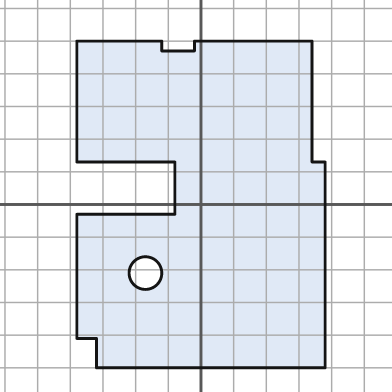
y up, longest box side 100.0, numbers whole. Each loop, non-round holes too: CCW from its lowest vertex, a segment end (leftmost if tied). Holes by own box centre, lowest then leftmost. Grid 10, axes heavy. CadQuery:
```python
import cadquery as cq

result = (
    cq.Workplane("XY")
    .moveTo(-32.0, -50.0)
    .lineTo(38.0, -50.0)
    .lineTo(38.0, 13.0)
    .lineTo(34.0, 13.0)
    .lineTo(34.0, 50.0)
    .lineTo(-2.0, 50.0)
    .lineTo(-2.0, 47.0)
    .lineTo(-12.0, 47.0)
    .lineTo(-12.0, 50.0)
    .lineTo(-38.0, 50.0)
    .lineTo(-38.0, 13.0)
    .lineTo(-8.0, 13.0)
    .lineTo(-8.0, -3.0)
    .lineTo(-38.0, -3.0)
    .lineTo(-38.0, -41.0)
    .lineTo(-32.0, -41.0)
    .close()
    .moveTo(-17.0, -21.0)
    .circle(5.0)
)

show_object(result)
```